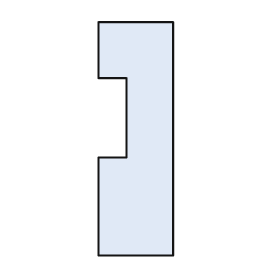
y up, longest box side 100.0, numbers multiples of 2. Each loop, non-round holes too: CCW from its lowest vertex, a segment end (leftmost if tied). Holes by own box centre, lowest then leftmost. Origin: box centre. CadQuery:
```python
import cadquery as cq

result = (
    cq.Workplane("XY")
    .moveTo(-16.0, -50.0)
    .lineTo(16.0, -50.0)
    .lineTo(16.0, 50.0)
    .lineTo(-16.0, 50.0)
    .lineTo(-16.0, 26.0)
    .lineTo(-4.0, 26.0)
    .lineTo(-4.0, -8.0)
    .lineTo(-16.0, -8.0)
    .close()
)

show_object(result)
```